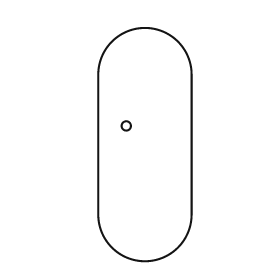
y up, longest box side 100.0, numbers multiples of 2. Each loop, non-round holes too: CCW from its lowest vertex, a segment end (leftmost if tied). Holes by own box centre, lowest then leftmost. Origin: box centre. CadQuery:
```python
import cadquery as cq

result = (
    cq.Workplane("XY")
    .moveTo(-20.0, -30.0)
    .threePointArc((0.0, -50.0), (20.0, -30.0))
    .lineTo(20.0, 30.0)
    .threePointArc((0.0, 50.0), (-20.0, 30.0))
    .close()
    .moveTo(-8.0, 8.0)
    .circle(2.0)
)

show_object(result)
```